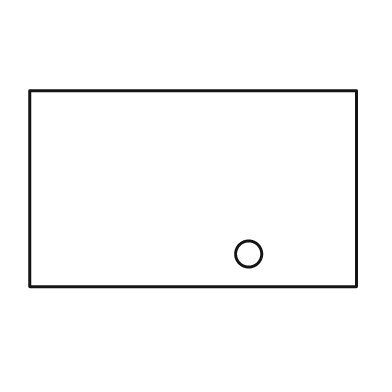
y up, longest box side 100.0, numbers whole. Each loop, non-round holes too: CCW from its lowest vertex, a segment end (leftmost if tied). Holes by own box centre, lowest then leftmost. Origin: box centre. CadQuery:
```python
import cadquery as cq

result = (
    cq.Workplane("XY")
    .moveTo(-50.0, -30.0)
    .lineTo(50.0, -30.0)
    .lineTo(50.0, 30.0)
    .lineTo(-50.0, 30.0)
    .close()
    .moveTo(17.0, -20.0)
    .circle(4.0)
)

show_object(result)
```